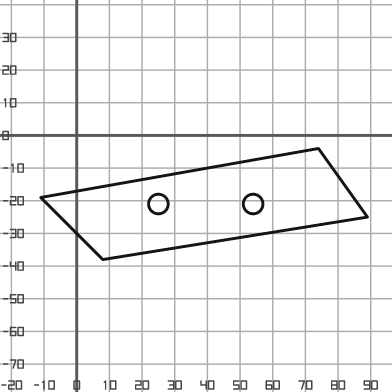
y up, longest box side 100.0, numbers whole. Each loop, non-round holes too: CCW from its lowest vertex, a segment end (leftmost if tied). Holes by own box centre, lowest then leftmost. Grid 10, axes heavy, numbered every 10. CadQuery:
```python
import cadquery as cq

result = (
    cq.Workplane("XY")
    .moveTo(8.0, -38.0)
    .lineTo(89.0, -25.0)
    .lineTo(74.0, -4.0)
    .lineTo(-11.0, -19.0)
    .close()
    .moveTo(25.0, -21.0)
    .circle(3.0)
    .moveTo(54.0, -21.0)
    .circle(3.0)
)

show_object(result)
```